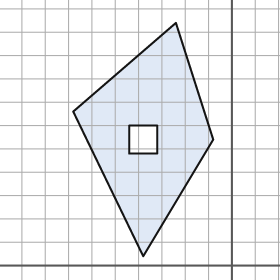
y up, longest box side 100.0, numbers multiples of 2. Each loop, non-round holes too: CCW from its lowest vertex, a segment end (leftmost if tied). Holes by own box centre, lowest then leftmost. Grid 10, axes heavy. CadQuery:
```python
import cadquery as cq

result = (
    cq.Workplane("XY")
    .moveTo(-38.0, 4.0)
    .lineTo(-8.0, 54.0)
    .lineTo(-24.0, 104.0)
    .lineTo(-68.0, 66.0)
    .close()
    .moveTo(-44.0, 48.0)
    .lineTo(-32.0, 48.0)
    .lineTo(-32.0, 60.0)
    .lineTo(-44.0, 60.0)
    .close()
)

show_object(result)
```